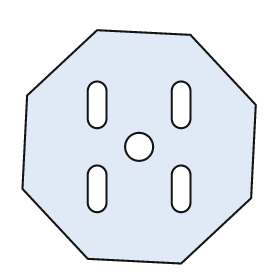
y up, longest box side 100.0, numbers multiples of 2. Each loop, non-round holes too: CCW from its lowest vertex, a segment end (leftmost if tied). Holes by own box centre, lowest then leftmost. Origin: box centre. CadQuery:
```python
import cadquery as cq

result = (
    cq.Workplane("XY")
    .moveTo(18.0, -50.0)
    .lineTo(48.0, -22.0)
    .lineTo(50.0, 18.0)
    .lineTo(22.0, 48.0)
    .lineTo(-18.0, 50.0)
    .lineTo(-48.0, 22.0)
    .lineTo(-50.0, -18.0)
    .lineTo(-22.0, -48.0)
    .close()
    .moveTo(-22.0, -24.0)
    .threePointArc((-18.0, -28.0), (-14.0, -24.0))
    .lineTo(-14.0, -12.0)
    .threePointArc((-18.0, -8.0), (-22.0, -12.0))
    .close()
    .moveTo(14.0, -24.0)
    .threePointArc((18.0, -28.0), (22.0, -24.0))
    .lineTo(22.0, -12.0)
    .threePointArc((18.0, -8.0), (14.0, -12.0))
    .close()
    .moveTo(0.0, 0.0)
    .circle(6.0)
    .moveTo(-22.0, 12.0)
    .threePointArc((-18.0, 8.0), (-14.0, 12.0))
    .lineTo(-14.0, 24.0)
    .threePointArc((-18.0, 28.0), (-22.0, 24.0))
    .close()
    .moveTo(14.0, 12.0)
    .threePointArc((18.0, 8.0), (22.0, 12.0))
    .lineTo(22.0, 24.0)
    .threePointArc((18.0, 28.0), (14.0, 24.0))
    .close()
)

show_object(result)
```